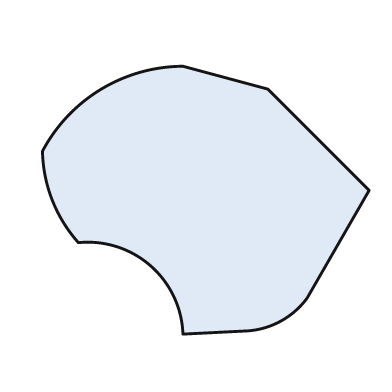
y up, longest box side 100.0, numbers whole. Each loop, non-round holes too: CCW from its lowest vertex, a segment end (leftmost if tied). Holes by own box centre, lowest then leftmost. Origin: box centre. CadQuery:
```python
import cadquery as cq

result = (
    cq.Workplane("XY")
    .moveTo(-7.0, -41.0)
    .lineTo(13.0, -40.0)
    .threePointArc((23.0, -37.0), (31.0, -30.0))
    .lineTo(50.0, 3.0)
    .lineTo(19.0, 34.0)
    .lineTo(-7.0, 41.0)
    .threePointArc((-32.0, 34.0), (-50.0, 15.0))
    .threePointArc((-47.0, 0.0), (-39.0, -13.0))
    .threePointArc((-17.0, -20.0), (-7.0, -41.0))
    .close()
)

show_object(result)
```